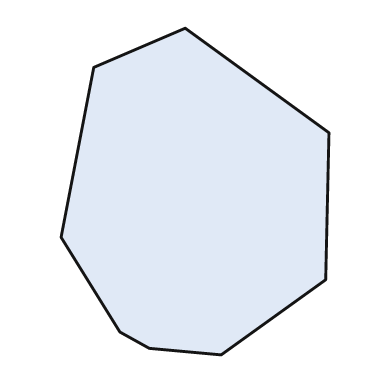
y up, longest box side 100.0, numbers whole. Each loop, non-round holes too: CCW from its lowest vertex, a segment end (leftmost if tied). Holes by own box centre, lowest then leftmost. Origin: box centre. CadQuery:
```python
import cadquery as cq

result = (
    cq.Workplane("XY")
    .moveTo(8.0, -50.0)
    .lineTo(40.0, -27.0)
    .lineTo(41.0, 18.0)
    .lineTo(-3.0, 50.0)
    .lineTo(-31.0, 38.0)
    .lineTo(-41.0, -14.0)
    .lineTo(-23.0, -43.0)
    .lineTo(-14.0, -48.0)
    .close()
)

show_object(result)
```